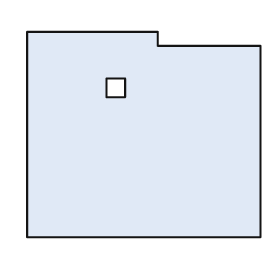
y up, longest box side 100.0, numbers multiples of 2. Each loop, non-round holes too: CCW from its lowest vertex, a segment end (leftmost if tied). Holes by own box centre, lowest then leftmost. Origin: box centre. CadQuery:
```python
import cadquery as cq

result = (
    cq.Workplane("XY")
    .moveTo(-50.0, -44.0)
    .lineTo(50.0, -44.0)
    .lineTo(50.0, 38.0)
    .lineTo(6.0, 38.0)
    .lineTo(6.0, 44.0)
    .lineTo(-50.0, 44.0)
    .close()
    .moveTo(-16.0, 16.0)
    .lineTo(-8.0, 16.0)
    .lineTo(-8.0, 24.0)
    .lineTo(-16.0, 24.0)
    .close()
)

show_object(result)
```